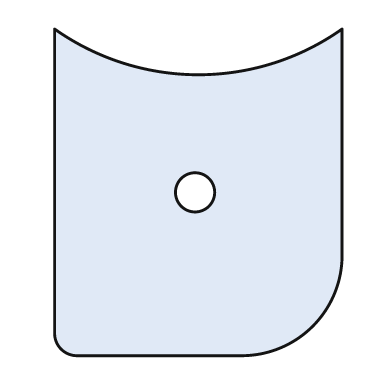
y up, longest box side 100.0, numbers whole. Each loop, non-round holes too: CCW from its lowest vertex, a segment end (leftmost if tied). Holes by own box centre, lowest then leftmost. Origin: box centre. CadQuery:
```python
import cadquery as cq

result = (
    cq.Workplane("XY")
    .moveTo(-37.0, -50.0)
    .lineTo(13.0, -50.0)
    .threePointArc((35.0, -41.0), (44.0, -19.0))
    .lineTo(44.0, 50.0)
    .threePointArc((0.0, 36.0), (-44.0, 50.0))
    .lineTo(-44.0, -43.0)
    .threePointArc((-42.0, -48.0), (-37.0, -50.0))
    .close()
    .moveTo(-1.0, 0.0)
    .circle(6.0)
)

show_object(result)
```